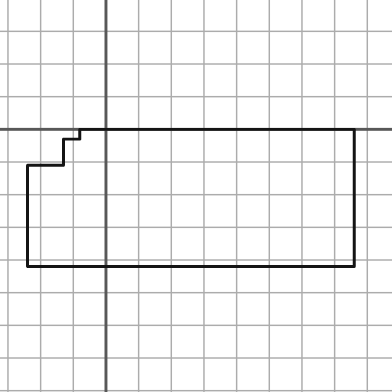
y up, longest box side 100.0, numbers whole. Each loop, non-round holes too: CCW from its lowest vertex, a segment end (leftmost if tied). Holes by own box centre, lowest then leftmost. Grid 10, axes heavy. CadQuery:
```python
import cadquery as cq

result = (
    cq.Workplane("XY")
    .moveTo(-24.0, -42.0)
    .lineTo(76.0, -42.0)
    .lineTo(76.0, 0.0)
    .lineTo(-8.0, 0.0)
    .lineTo(-8.0, -3.0)
    .lineTo(-13.0, -3.0)
    .lineTo(-13.0, -11.0)
    .lineTo(-24.0, -11.0)
    .close()
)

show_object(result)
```